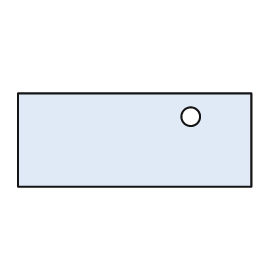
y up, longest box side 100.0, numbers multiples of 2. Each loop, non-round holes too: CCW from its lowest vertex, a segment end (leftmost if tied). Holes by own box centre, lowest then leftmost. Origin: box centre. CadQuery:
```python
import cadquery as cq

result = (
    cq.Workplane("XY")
    .moveTo(-50.0, -20.0)
    .lineTo(50.0, -20.0)
    .lineTo(50.0, 20.0)
    .lineTo(-50.0, 20.0)
    .close()
    .moveTo(24.0, 10.0)
    .circle(4.0)
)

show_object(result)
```